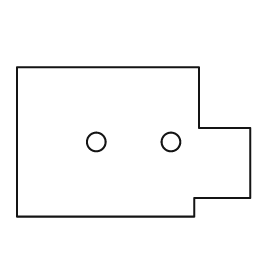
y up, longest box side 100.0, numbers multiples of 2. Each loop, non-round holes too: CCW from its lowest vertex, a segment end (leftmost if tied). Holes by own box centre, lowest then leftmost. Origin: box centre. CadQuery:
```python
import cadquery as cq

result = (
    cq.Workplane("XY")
    .moveTo(-50.0, -32.0)
    .lineTo(26.0, -32.0)
    .lineTo(26.0, -24.0)
    .lineTo(50.0, -24.0)
    .lineTo(50.0, 6.0)
    .lineTo(28.0, 6.0)
    .lineTo(28.0, 32.0)
    .lineTo(-50.0, 32.0)
    .close()
    .moveTo(-16.0, 0.0)
    .circle(4.0)
    .moveTo(16.0, 0.0)
    .circle(4.0)
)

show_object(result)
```